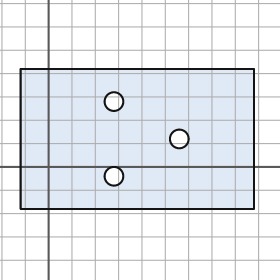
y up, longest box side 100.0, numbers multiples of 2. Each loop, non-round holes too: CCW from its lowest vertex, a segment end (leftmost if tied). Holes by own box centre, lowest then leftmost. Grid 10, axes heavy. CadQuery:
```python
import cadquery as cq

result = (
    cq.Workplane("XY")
    .moveTo(-12.0, -18.0)
    .lineTo(88.0, -18.0)
    .lineTo(88.0, 42.0)
    .lineTo(-12.0, 42.0)
    .close()
    .moveTo(28.0, -4.0)
    .circle(4.0)
    .moveTo(56.0, 12.0)
    .circle(4.0)
    .moveTo(28.0, 28.0)
    .circle(4.0)
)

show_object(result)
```